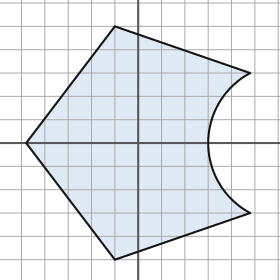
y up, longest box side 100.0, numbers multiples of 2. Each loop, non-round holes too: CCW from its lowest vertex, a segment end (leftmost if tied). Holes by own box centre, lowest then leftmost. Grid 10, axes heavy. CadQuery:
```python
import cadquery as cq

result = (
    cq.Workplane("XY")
    .moveTo(-10.0, -50.0)
    .lineTo(48.0, -30.0)
    .threePointArc((30.0, 0.0), (48.0, 30.0))
    .lineTo(-10.0, 50.0)
    .lineTo(-48.0, 0.0)
    .close()
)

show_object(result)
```